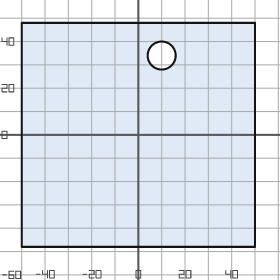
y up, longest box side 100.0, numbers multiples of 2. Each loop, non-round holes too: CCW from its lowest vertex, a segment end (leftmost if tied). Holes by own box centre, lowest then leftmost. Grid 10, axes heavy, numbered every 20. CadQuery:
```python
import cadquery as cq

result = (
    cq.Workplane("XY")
    .moveTo(-50.0, -48.0)
    .lineTo(50.0, -48.0)
    .lineTo(50.0, 48.0)
    .lineTo(-50.0, 48.0)
    .close()
    .moveTo(10.0, 34.0)
    .circle(6.0)
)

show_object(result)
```